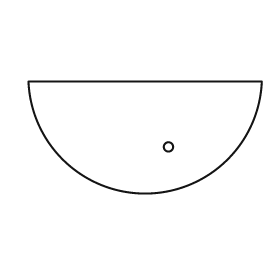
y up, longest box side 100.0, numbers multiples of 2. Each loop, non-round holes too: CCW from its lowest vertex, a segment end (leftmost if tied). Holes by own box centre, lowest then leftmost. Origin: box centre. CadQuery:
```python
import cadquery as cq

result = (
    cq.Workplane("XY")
    .moveTo(-50.0, 24.0)
    .threePointArc((0.0, -24.0), (50.0, 24.0))
    .close()
    .moveTo(10.0, -4.0)
    .circle(2.0)
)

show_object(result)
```